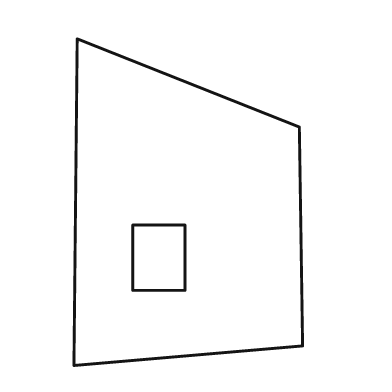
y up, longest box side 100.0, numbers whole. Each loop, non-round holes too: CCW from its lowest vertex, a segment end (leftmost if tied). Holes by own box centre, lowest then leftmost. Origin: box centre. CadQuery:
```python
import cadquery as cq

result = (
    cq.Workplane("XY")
    .moveTo(-35.0, -50.0)
    .lineTo(35.0, -44.0)
    .lineTo(34.0, 23.0)
    .lineTo(-34.0, 50.0)
    .close()
    .moveTo(-17.0, -27.0)
    .lineTo(-1.0, -27.0)
    .lineTo(-1.0, -7.0)
    .lineTo(-17.0, -7.0)
    .close()
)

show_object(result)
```